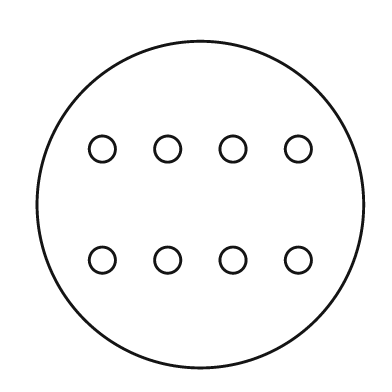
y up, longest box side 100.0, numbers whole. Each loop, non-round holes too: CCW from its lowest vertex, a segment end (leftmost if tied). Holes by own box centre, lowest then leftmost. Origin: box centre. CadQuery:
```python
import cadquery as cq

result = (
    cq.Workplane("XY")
    .moveTo(0.0, 0.0)
    .circle(50.0)
    .moveTo(-30.0, -17.0)
    .circle(4.0)
    .moveTo(-10.0, -17.0)
    .circle(4.0)
    .moveTo(10.0, -17.0)
    .circle(4.0)
    .moveTo(30.0, -17.0)
    .circle(4.0)
    .moveTo(-30.0, 17.0)
    .circle(4.0)
    .moveTo(-10.0, 17.0)
    .circle(4.0)
    .moveTo(10.0, 17.0)
    .circle(4.0)
    .moveTo(30.0, 17.0)
    .circle(4.0)
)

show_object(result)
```